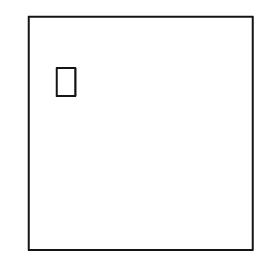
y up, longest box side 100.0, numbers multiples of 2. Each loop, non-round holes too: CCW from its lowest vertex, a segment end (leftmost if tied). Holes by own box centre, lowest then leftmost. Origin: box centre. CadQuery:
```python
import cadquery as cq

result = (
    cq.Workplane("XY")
    .moveTo(-48.0, -50.0)
    .lineTo(48.0, -50.0)
    .lineTo(48.0, 50.0)
    .lineTo(-48.0, 50.0)
    .close()
    .moveTo(-36.0, 16.0)
    .lineTo(-28.0, 16.0)
    .lineTo(-28.0, 28.0)
    .lineTo(-36.0, 28.0)
    .close()
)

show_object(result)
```